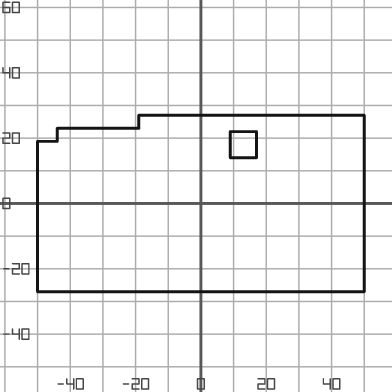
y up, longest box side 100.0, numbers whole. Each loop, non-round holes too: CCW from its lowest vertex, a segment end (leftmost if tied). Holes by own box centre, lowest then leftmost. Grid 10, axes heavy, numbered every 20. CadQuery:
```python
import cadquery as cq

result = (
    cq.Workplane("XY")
    .moveTo(-50.0, -27.0)
    .lineTo(50.0, -27.0)
    .lineTo(50.0, 27.0)
    .lineTo(-19.0, 27.0)
    .lineTo(-19.0, 23.0)
    .lineTo(-44.0, 23.0)
    .lineTo(-44.0, 19.0)
    .lineTo(-50.0, 19.0)
    .close()
    .moveTo(9.0, 14.0)
    .lineTo(17.0, 14.0)
    .lineTo(17.0, 22.0)
    .lineTo(9.0, 22.0)
    .close()
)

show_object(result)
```